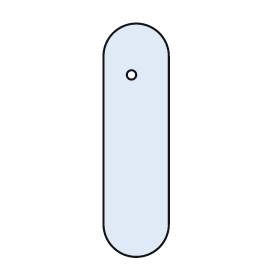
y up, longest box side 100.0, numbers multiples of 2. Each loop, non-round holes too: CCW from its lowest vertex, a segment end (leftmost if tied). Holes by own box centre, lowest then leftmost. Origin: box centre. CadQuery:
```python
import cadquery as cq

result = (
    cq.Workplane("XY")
    .moveTo(-14.0, -36.0)
    .threePointArc((0.0, -50.0), (14.0, -36.0))
    .lineTo(14.0, 36.0)
    .threePointArc((0.0, 50.0), (-14.0, 36.0))
    .close()
    .moveTo(-2.0, 28.0)
    .circle(2.0)
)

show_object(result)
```